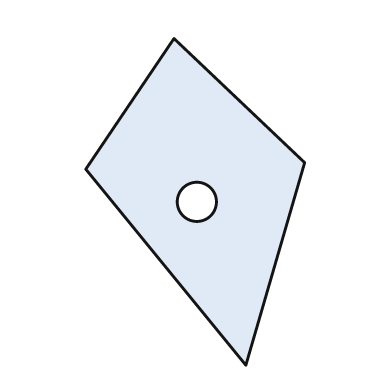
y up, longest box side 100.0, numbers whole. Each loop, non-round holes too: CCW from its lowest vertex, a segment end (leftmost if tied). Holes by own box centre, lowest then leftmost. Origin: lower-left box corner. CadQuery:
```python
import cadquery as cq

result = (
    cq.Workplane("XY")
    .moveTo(49.0, 0.0)
    .lineTo(67.0, 62.0)
    .lineTo(27.0, 100.0)
    .lineTo(0.0, 60.0)
    .close()
    .moveTo(34.0, 50.0)
    .circle(6.0)
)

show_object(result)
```